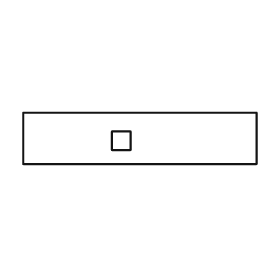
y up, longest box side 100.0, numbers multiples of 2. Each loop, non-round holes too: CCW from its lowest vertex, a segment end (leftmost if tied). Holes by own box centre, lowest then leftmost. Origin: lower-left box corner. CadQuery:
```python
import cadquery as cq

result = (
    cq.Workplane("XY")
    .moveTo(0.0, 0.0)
    .lineTo(100.0, 0.0)
    .lineTo(100.0, 22.0)
    .lineTo(0.0, 22.0)
    .close()
    .moveTo(38.0, 6.0)
    .lineTo(46.0, 6.0)
    .lineTo(46.0, 14.0)
    .lineTo(38.0, 14.0)
    .close()
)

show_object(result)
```